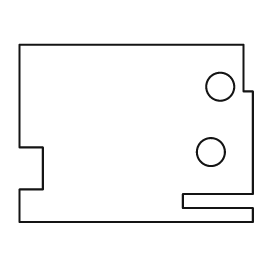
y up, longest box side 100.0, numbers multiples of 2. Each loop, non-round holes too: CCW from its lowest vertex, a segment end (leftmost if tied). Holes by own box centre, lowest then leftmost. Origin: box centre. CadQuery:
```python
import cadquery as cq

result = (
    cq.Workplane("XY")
    .moveTo(-50.0, -38.0)
    .lineTo(50.0, -38.0)
    .lineTo(50.0, -32.0)
    .lineTo(20.0, -32.0)
    .lineTo(20.0, -26.0)
    .lineTo(50.0, -26.0)
    .lineTo(50.0, 18.0)
    .lineTo(46.0, 18.0)
    .lineTo(46.0, 38.0)
    .lineTo(-50.0, 38.0)
    .lineTo(-50.0, -6.0)
    .lineTo(-40.0, -6.0)
    .lineTo(-40.0, -24.0)
    .lineTo(-50.0, -24.0)
    .close()
    .moveTo(32.0, -8.0)
    .circle(6.0)
    .moveTo(36.0, 20.0)
    .circle(6.0)
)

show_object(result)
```